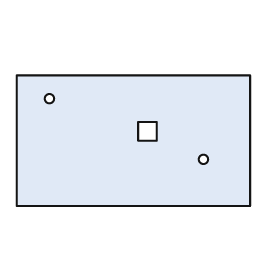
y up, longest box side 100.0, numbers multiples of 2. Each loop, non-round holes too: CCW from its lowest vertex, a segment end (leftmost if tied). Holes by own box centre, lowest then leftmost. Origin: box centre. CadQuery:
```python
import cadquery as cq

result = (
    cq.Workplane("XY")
    .moveTo(-50.0, -28.0)
    .lineTo(50.0, -28.0)
    .lineTo(50.0, 28.0)
    .lineTo(-50.0, 28.0)
    .close()
    .moveTo(30.0, -8.0)
    .circle(2.0)
    .moveTo(2.0, 0.0)
    .lineTo(10.0, 0.0)
    .lineTo(10.0, 8.0)
    .lineTo(2.0, 8.0)
    .close()
    .moveTo(-36.0, 18.0)
    .circle(2.0)
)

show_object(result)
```